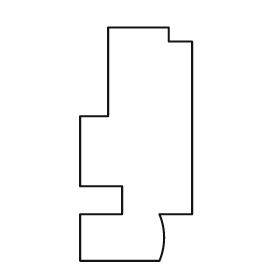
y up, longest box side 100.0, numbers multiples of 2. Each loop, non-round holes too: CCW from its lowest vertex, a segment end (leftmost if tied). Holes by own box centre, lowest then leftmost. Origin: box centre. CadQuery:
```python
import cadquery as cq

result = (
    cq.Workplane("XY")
    .moveTo(-24.0, -50.0)
    .lineTo(10.0, -50.0)
    .threePointArc((12.0, -40.0), (10.0, -30.0))
    .lineTo(24.0, -30.0)
    .lineTo(24.0, 44.0)
    .lineTo(14.0, 44.0)
    .lineTo(14.0, 50.0)
    .lineTo(-12.0, 50.0)
    .lineTo(-12.0, 12.0)
    .lineTo(-24.0, 12.0)
    .lineTo(-24.0, -18.0)
    .lineTo(-6.0, -18.0)
    .lineTo(-6.0, -30.0)
    .lineTo(-24.0, -30.0)
    .close()
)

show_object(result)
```